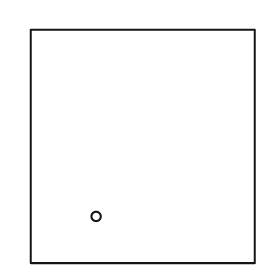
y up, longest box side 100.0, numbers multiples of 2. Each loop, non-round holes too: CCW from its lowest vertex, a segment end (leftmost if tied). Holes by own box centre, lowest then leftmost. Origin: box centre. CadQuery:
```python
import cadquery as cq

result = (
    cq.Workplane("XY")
    .moveTo(-48.0, -50.0)
    .lineTo(48.0, -50.0)
    .lineTo(48.0, 50.0)
    .lineTo(-48.0, 50.0)
    .close()
    .moveTo(-20.0, -30.0)
    .circle(2.0)
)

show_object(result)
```